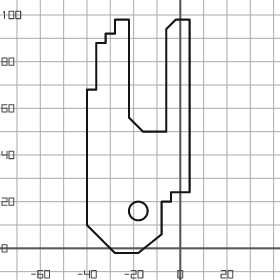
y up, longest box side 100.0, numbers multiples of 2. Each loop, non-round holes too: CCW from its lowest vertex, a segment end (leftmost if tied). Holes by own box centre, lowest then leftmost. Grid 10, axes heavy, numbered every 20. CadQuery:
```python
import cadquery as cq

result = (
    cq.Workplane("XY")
    .moveTo(-28.0, -2.0)
    .lineTo(-18.0, -2.0)
    .lineTo(-8.0, 6.0)
    .lineTo(-8.0, 20.0)
    .lineTo(-4.0, 20.0)
    .lineTo(-4.0, 24.0)
    .lineTo(4.0, 24.0)
    .lineTo(4.0, 98.0)
    .lineTo(-2.0, 98.0)
    .lineTo(-6.0, 94.0)
    .lineTo(-6.0, 50.0)
    .lineTo(-16.0, 50.0)
    .lineTo(-22.0, 56.0)
    .lineTo(-22.0, 98.0)
    .lineTo(-28.0, 98.0)
    .lineTo(-28.0, 92.0)
    .lineTo(-32.0, 92.0)
    .lineTo(-32.0, 88.0)
    .lineTo(-36.0, 88.0)
    .lineTo(-36.0, 68.0)
    .lineTo(-40.0, 68.0)
    .lineTo(-40.0, 10.0)
    .close()
    .moveTo(-18.0, 16.0)
    .circle(4.0)
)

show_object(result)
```